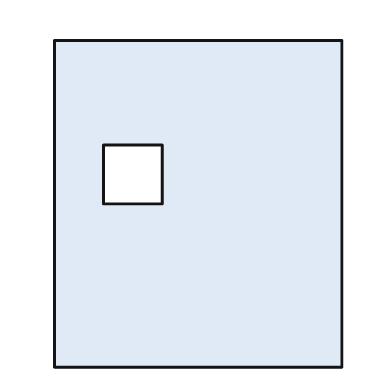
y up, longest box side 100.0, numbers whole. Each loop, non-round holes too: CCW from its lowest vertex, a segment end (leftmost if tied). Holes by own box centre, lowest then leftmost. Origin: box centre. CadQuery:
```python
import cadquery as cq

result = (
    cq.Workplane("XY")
    .moveTo(-44.0, -50.0)
    .lineTo(44.0, -50.0)
    .lineTo(44.0, 50.0)
    .lineTo(-44.0, 50.0)
    .close()
    .moveTo(-29.0, 0.0)
    .lineTo(-11.0, 0.0)
    .lineTo(-11.0, 18.0)
    .lineTo(-29.0, 18.0)
    .close()
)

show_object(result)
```